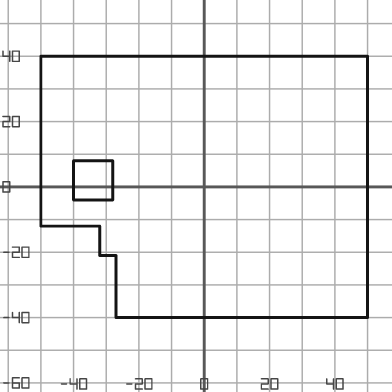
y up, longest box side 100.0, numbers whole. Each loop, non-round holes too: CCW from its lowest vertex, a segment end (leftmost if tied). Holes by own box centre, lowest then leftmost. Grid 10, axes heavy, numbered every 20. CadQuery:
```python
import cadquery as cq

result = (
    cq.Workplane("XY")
    .moveTo(-27.0, -40.0)
    .lineTo(50.0, -40.0)
    .lineTo(50.0, 40.0)
    .lineTo(-50.0, 40.0)
    .lineTo(-50.0, -12.0)
    .lineTo(-32.0, -12.0)
    .lineTo(-32.0, -21.0)
    .lineTo(-27.0, -21.0)
    .close()
    .moveTo(-40.0, -4.0)
    .lineTo(-28.0, -4.0)
    .lineTo(-28.0, 8.0)
    .lineTo(-40.0, 8.0)
    .close()
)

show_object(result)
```